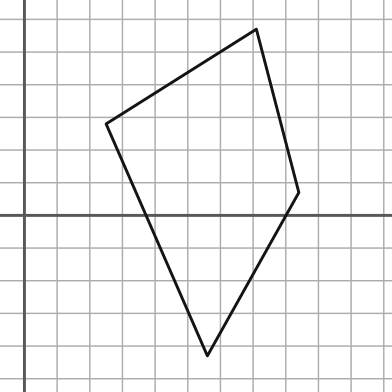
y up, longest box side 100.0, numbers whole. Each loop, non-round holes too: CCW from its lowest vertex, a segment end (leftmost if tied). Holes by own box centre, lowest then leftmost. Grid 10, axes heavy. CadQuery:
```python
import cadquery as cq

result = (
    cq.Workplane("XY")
    .moveTo(56.0, -43.0)
    .lineTo(84.0, 7.0)
    .lineTo(71.0, 57.0)
    .lineTo(25.0, 28.0)
    .close()
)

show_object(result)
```